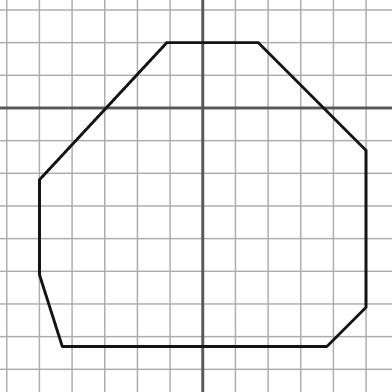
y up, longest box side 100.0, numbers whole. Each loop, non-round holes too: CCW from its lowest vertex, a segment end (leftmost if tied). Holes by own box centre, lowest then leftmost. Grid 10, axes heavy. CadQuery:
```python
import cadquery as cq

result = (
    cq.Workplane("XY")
    .moveTo(-43.0, -73.0)
    .lineTo(38.0, -73.0)
    .lineTo(50.0, -61.0)
    .lineTo(50.0, -13.0)
    .lineTo(17.0, 20.0)
    .lineTo(-11.0, 20.0)
    .lineTo(-50.0, -22.0)
    .lineTo(-50.0, -51.0)
    .close()
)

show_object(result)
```